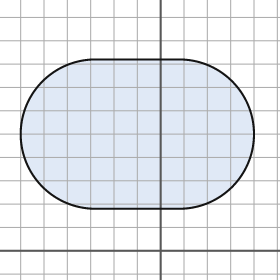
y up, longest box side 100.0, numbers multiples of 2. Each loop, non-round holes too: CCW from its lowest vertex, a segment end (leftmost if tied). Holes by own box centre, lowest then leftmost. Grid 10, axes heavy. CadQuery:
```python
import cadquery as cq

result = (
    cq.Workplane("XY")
    .moveTo(-28.0, 18.0)
    .lineTo(8.0, 18.0)
    .threePointArc((40.0, 50.0), (8.0, 82.0))
    .lineTo(-28.0, 82.0)
    .threePointArc((-60.0, 50.0), (-28.0, 18.0))
    .close()
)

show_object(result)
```